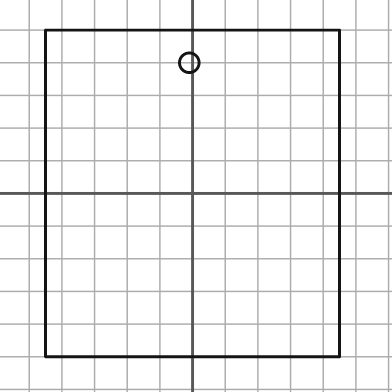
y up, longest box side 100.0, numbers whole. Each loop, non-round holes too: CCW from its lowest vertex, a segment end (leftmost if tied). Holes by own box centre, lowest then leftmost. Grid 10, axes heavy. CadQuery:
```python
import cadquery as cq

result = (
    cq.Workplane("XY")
    .moveTo(-45.0, -50.0)
    .lineTo(45.0, -50.0)
    .lineTo(45.0, 50.0)
    .lineTo(-45.0, 50.0)
    .close()
    .moveTo(-1.0, 40.0)
    .circle(3.0)
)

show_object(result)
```